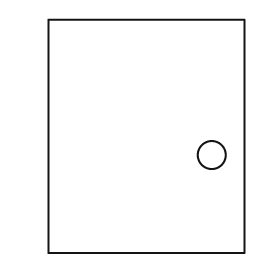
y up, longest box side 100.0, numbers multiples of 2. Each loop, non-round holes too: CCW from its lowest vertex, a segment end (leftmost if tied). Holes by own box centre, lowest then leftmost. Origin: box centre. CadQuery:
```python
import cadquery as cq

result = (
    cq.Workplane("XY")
    .moveTo(-42.0, -50.0)
    .lineTo(42.0, -50.0)
    .lineTo(42.0, 50.0)
    .lineTo(-42.0, 50.0)
    .close()
    .moveTo(28.0, -8.0)
    .circle(6.0)
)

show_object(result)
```